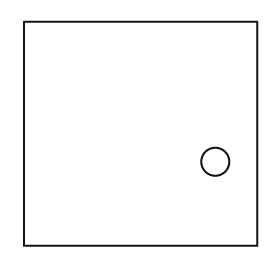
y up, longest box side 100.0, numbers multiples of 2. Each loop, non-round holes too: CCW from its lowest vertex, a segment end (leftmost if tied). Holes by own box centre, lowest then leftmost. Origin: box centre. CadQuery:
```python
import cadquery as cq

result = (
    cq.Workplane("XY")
    .moveTo(-50.0, -48.0)
    .lineTo(50.0, -48.0)
    .lineTo(50.0, 48.0)
    .lineTo(-50.0, 48.0)
    .close()
    .moveTo(32.0, -12.0)
    .circle(6.0)
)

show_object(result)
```